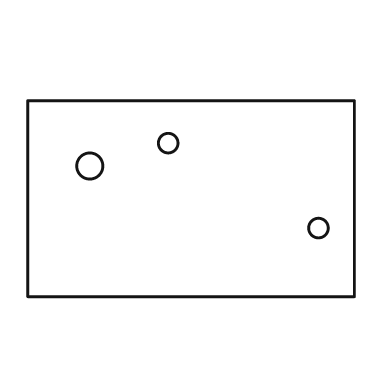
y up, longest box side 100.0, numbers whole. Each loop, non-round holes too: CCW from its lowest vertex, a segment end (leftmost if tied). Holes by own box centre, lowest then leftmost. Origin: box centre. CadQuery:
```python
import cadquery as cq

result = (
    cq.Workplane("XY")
    .moveTo(-50.0, -30.0)
    .lineTo(50.0, -30.0)
    .lineTo(50.0, 30.0)
    .lineTo(-50.0, 30.0)
    .close()
    .moveTo(39.0, -9.0)
    .circle(3.0)
    .moveTo(-31.0, 10.0)
    .circle(4.0)
    .moveTo(-7.0, 17.0)
    .circle(3.0)
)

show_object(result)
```